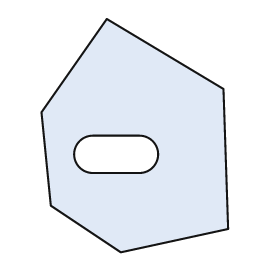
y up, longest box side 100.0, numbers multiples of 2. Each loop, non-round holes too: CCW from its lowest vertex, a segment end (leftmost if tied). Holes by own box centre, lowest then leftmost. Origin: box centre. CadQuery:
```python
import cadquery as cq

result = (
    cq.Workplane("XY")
    .moveTo(-6.0, -50.0)
    .lineTo(40.0, -40.0)
    .lineTo(38.0, 20.0)
    .lineTo(-12.0, 50.0)
    .lineTo(-40.0, 10.0)
    .lineTo(-36.0, -30.0)
    .close()
    .moveTo(-18.0, -16.0)
    .lineTo(2.0, -16.0)
    .threePointArc((10.0, -8.0), (2.0, 0.0))
    .lineTo(-18.0, 0.0)
    .threePointArc((-26.0, -8.0), (-18.0, -16.0))
    .close()
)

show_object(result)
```